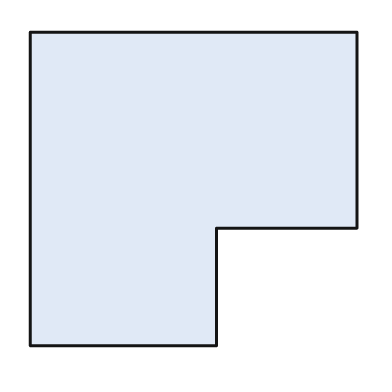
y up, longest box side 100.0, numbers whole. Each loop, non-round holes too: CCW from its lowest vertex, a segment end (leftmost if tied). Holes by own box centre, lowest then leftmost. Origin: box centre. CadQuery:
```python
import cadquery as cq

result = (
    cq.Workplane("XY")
    .moveTo(-50.0, -48.0)
    .lineTo(7.0, -48.0)
    .lineTo(7.0, -12.0)
    .lineTo(50.0, -12.0)
    .lineTo(50.0, 48.0)
    .lineTo(-50.0, 48.0)
    .close()
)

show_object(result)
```